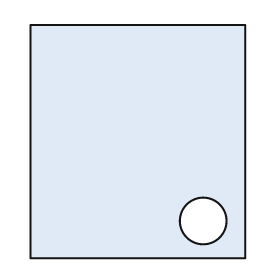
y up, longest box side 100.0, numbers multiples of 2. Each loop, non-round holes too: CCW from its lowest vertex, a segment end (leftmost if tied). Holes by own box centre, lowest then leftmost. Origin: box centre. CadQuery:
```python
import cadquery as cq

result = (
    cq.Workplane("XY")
    .moveTo(-46.0, -50.0)
    .lineTo(46.0, -50.0)
    .lineTo(46.0, 50.0)
    .lineTo(-46.0, 50.0)
    .close()
    .moveTo(28.0, -34.0)
    .circle(10.0)
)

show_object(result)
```